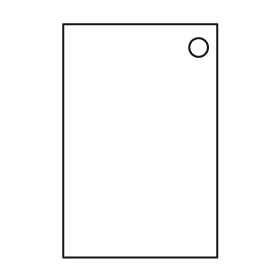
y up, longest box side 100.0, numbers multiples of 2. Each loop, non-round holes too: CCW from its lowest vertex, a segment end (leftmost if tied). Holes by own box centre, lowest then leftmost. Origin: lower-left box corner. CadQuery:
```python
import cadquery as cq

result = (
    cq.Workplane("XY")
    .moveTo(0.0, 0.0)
    .lineTo(66.0, 0.0)
    .lineTo(66.0, 100.0)
    .lineTo(0.0, 100.0)
    .close()
    .moveTo(58.0, 90.0)
    .circle(4.0)
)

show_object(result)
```